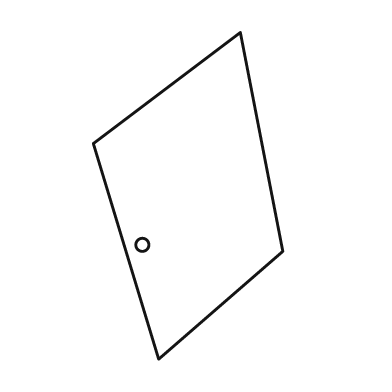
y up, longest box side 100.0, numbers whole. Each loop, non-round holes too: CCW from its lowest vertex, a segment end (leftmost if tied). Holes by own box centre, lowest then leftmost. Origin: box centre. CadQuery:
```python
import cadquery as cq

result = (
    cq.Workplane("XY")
    .moveTo(-9.0, -50.0)
    .lineTo(29.0, -17.0)
    .lineTo(16.0, 50.0)
    .lineTo(-29.0, 16.0)
    .close()
    .moveTo(-14.0, -15.0)
    .circle(2.0)
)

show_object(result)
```